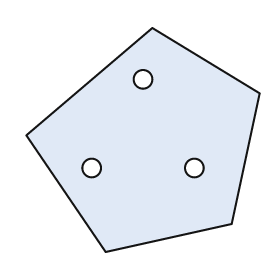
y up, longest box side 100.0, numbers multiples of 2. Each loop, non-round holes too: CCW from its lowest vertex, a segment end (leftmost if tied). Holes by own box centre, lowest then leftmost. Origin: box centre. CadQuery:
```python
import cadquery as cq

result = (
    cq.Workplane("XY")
    .moveTo(-16.0, -48.0)
    .lineTo(38.0, -36.0)
    .lineTo(50.0, 20.0)
    .lineTo(4.0, 48.0)
    .lineTo(-50.0, 2.0)
    .close()
    .moveTo(-22.0, -12.0)
    .circle(4.0)
    .moveTo(22.0, -12.0)
    .circle(4.0)
    .moveTo(0.0, 26.0)
    .circle(4.0)
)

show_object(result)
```